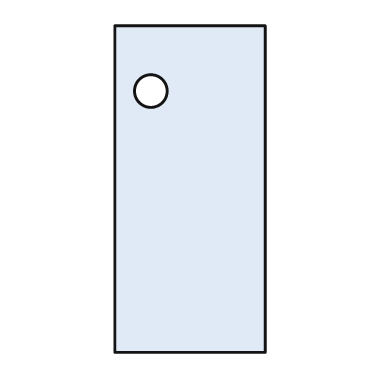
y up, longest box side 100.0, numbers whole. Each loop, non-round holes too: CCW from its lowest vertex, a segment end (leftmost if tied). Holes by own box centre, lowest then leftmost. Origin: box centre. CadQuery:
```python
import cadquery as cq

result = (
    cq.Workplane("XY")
    .moveTo(-23.0, -50.0)
    .lineTo(23.0, -50.0)
    .lineTo(23.0, 50.0)
    .lineTo(-23.0, 50.0)
    .close()
    .moveTo(-12.0, 30.0)
    .circle(5.0)
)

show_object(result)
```